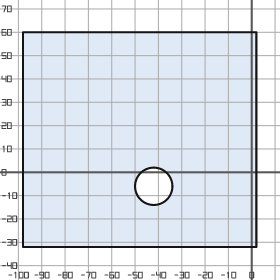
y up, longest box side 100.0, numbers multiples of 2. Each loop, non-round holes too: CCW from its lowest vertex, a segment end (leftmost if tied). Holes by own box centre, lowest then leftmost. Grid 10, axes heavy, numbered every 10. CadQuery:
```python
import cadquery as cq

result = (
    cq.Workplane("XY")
    .moveTo(-98.0, -32.0)
    .lineTo(2.0, -32.0)
    .lineTo(2.0, 60.0)
    .lineTo(-98.0, 60.0)
    .close()
    .moveTo(-42.0, -6.0)
    .circle(8.0)
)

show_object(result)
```